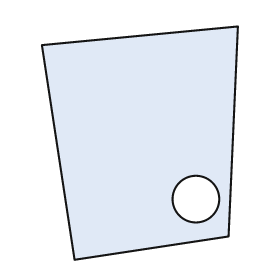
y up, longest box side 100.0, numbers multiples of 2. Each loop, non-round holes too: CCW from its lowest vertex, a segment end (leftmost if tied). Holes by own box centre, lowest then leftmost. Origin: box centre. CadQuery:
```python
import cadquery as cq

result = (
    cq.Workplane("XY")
    .moveTo(-28.0, -50.0)
    .lineTo(38.0, -40.0)
    .lineTo(42.0, 50.0)
    .lineTo(-42.0, 42.0)
    .close()
    .moveTo(24.0, -24.0)
    .circle(10.0)
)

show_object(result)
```